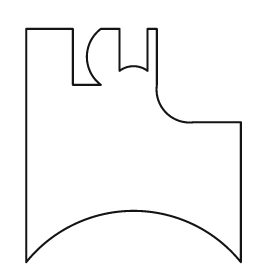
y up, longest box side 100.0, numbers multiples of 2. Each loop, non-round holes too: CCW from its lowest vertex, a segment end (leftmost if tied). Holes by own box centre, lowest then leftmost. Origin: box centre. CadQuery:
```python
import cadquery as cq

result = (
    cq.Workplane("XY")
    .moveTo(-46.0, -50.0)
    .threePointArc((0.0, -28.0), (46.0, -50.0))
    .lineTo(46.0, 10.0)
    .lineTo(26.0, 10.0)
    .threePointArc((14.0, 14.0), (10.0, 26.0))
    .lineTo(10.0, 50.0)
    .lineTo(6.0, 50.0)
    .lineTo(6.0, 32.0)
    .threePointArc((0.0, 34.0), (-6.0, 32.0))
    .lineTo(-6.0, 50.0)
    .lineTo(-14.0, 50.0)
    .threePointArc((-20.0, 38.0), (-14.0, 26.0))
    .lineTo(-26.0, 26.0)
    .lineTo(-26.0, 50.0)
    .lineTo(-46.0, 50.0)
    .close()
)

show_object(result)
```